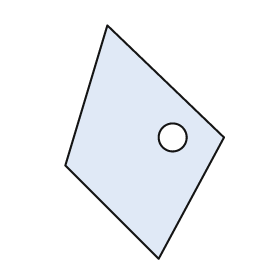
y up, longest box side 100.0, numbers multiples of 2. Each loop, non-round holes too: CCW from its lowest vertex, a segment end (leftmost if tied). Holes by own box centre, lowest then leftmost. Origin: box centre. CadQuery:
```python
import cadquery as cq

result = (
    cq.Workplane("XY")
    .moveTo(6.0, -50.0)
    .lineTo(34.0, 2.0)
    .lineTo(-16.0, 50.0)
    .lineTo(-34.0, -10.0)
    .close()
    .moveTo(12.0, 2.0)
    .circle(6.0)
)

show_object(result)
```